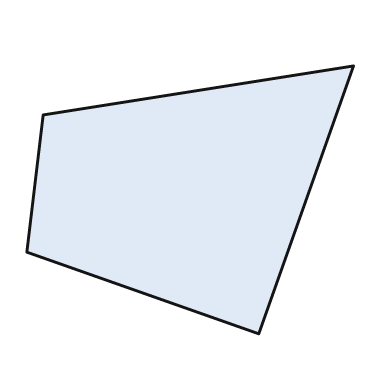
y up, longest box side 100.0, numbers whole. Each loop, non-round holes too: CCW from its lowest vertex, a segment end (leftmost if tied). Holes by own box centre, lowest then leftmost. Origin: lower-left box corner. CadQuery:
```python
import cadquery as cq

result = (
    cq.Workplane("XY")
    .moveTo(71.0, 0.0)
    .lineTo(100.0, 82.0)
    .lineTo(5.0, 67.0)
    .lineTo(0.0, 25.0)
    .close()
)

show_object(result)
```